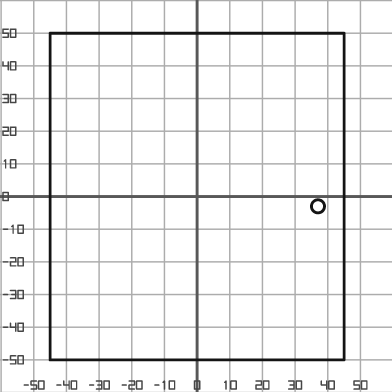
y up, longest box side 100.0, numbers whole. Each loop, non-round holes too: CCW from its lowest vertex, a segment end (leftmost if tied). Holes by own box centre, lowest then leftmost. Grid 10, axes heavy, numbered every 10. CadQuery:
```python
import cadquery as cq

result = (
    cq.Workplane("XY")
    .moveTo(-45.0, -50.0)
    .lineTo(45.0, -50.0)
    .lineTo(45.0, 50.0)
    .lineTo(-45.0, 50.0)
    .close()
    .moveTo(37.0, -3.0)
    .circle(2.0)
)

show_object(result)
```